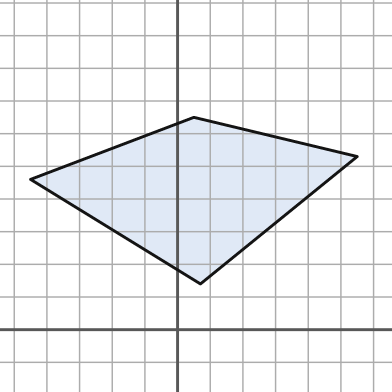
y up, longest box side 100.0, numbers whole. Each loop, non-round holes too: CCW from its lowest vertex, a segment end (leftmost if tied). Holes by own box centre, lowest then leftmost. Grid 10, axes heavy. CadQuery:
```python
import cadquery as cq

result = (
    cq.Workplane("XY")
    .moveTo(7.0, 14.0)
    .lineTo(55.0, 53.0)
    .lineTo(5.0, 65.0)
    .lineTo(-45.0, 46.0)
    .close()
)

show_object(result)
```